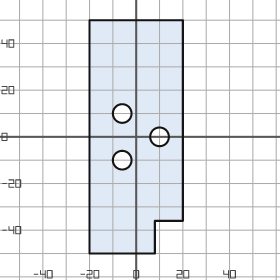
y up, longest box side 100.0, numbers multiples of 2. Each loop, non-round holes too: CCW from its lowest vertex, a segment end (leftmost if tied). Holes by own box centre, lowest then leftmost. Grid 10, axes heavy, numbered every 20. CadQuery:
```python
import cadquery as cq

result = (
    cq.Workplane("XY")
    .moveTo(-20.0, -50.0)
    .lineTo(8.0, -50.0)
    .lineTo(8.0, -36.0)
    .lineTo(20.0, -36.0)
    .lineTo(20.0, 50.0)
    .lineTo(-20.0, 50.0)
    .close()
    .moveTo(-6.0, -10.0)
    .circle(4.0)
    .moveTo(10.0, 0.0)
    .circle(4.0)
    .moveTo(-6.0, 10.0)
    .circle(4.0)
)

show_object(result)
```